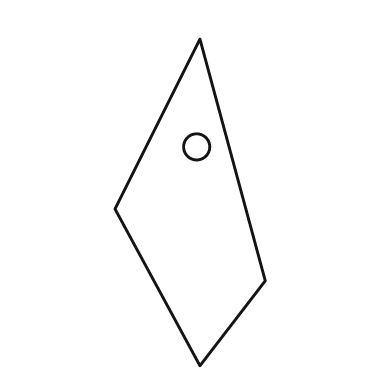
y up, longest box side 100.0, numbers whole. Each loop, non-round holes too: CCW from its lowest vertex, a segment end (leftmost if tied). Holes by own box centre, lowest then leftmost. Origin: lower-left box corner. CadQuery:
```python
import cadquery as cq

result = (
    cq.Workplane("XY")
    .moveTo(26.0, 0.0)
    .lineTo(46.0, 26.0)
    .lineTo(26.0, 100.0)
    .lineTo(0.0, 48.0)
    .close()
    .moveTo(25.0, 67.0)
    .circle(4.0)
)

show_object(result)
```